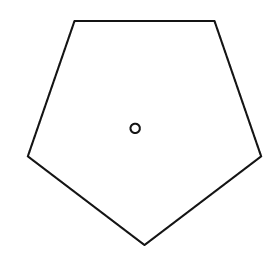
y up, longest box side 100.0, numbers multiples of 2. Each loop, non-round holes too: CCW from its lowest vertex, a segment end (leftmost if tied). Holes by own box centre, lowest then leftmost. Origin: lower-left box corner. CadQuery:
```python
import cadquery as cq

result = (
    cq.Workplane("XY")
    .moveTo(50.0, 0.0)
    .lineTo(100.0, 38.0)
    .lineTo(80.0, 96.0)
    .lineTo(20.0, 96.0)
    .lineTo(0.0, 38.0)
    .close()
    .moveTo(46.0, 50.0)
    .circle(2.0)
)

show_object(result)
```